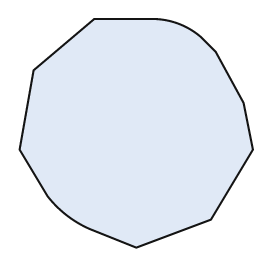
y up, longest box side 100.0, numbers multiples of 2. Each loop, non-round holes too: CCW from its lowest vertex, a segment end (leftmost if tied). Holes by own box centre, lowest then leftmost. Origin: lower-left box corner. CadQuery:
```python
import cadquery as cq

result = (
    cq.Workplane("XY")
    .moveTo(50.0, 0.0)
    .lineTo(82.0, 12.0)
    .lineTo(100.0, 42.0)
    .lineTo(96.0, 62.0)
    .lineTo(84.0, 84.0)
    .lineTo(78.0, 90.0)
    .threePointArc((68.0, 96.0), (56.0, 98.0))
    .lineTo(32.0, 98.0)
    .lineTo(6.0, 76.0)
    .lineTo(0.0, 42.0)
    .lineTo(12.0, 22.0)
    .threePointArc((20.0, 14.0), (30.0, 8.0))
    .close()
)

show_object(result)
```